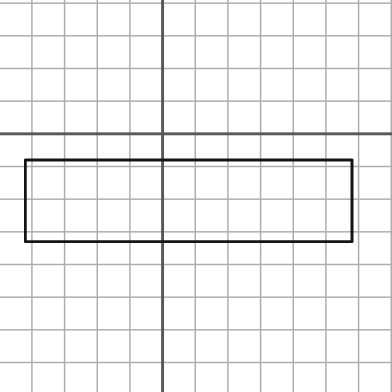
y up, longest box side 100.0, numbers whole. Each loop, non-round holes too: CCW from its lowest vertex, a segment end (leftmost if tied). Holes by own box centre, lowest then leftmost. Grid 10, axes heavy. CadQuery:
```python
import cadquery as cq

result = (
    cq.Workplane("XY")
    .moveTo(-42.0, -33.0)
    .lineTo(58.0, -33.0)
    .lineTo(58.0, -8.0)
    .lineTo(-42.0, -8.0)
    .close()
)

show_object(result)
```